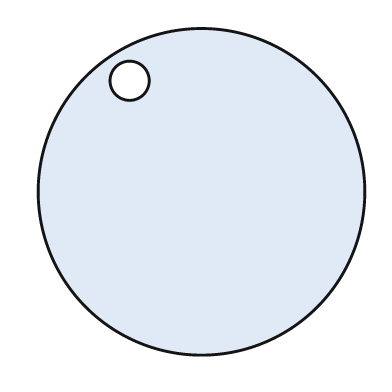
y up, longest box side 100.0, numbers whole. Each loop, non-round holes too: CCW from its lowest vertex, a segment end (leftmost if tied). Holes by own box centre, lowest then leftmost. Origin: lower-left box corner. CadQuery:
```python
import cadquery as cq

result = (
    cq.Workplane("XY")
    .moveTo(50.0, 50.0)
    .circle(50.0)
    .moveTo(28.0, 84.0)
    .circle(6.0)
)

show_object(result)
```